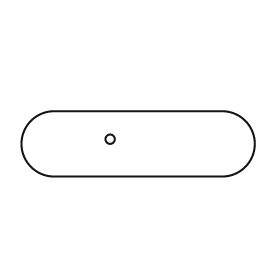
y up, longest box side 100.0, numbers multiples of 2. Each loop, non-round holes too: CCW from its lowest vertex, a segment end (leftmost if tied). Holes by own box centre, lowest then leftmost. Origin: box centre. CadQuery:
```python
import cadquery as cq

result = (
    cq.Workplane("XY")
    .moveTo(-36.0, -14.0)
    .lineTo(36.0, -14.0)
    .threePointArc((50.0, 0.0), (36.0, 14.0))
    .lineTo(-36.0, 14.0)
    .threePointArc((-50.0, 0.0), (-36.0, -14.0))
    .close()
    .moveTo(-12.0, 2.0)
    .circle(2.0)
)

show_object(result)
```